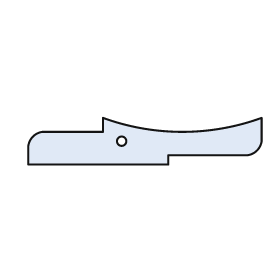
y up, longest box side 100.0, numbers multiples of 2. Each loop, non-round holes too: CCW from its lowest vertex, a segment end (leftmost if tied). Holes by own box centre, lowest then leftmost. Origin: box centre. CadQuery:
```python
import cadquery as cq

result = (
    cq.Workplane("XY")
    .moveTo(-50.0, -10.0)
    .lineTo(10.0, -10.0)
    .lineTo(10.0, -6.0)
    .lineTo(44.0, -6.0)
    .threePointArc((48.0, -4.0), (50.0, 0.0))
    .lineTo(50.0, 10.0)
    .threePointArc((16.0, 4.0), (-18.0, 10.0))
    .lineTo(-18.0, 4.0)
    .lineTo(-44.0, 4.0)
    .threePointArc((-48.0, 2.0), (-50.0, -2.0))
    .close()
    .moveTo(-10.0, 0.0)
    .circle(2.0)
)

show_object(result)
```